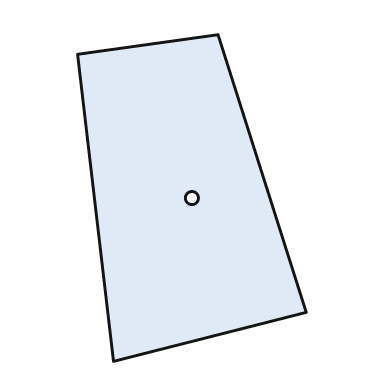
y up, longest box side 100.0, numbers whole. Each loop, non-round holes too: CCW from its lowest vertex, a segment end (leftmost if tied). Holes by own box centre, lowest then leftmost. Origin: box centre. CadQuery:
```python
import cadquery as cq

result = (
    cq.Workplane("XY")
    .moveTo(-24.0, -50.0)
    .lineTo(35.0, -35.0)
    .lineTo(8.0, 50.0)
    .lineTo(-35.0, 44.0)
    .close()
    .moveTo(0.0, 0.0)
    .circle(2.0)
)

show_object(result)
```